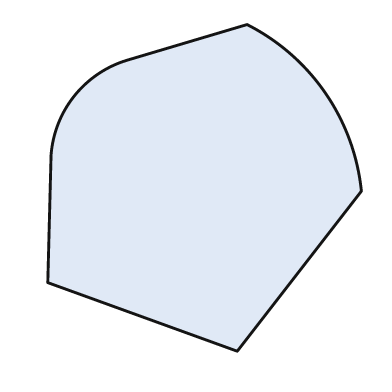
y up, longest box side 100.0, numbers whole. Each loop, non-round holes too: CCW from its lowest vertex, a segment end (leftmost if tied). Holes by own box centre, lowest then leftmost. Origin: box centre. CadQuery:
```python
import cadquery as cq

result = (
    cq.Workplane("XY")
    .moveTo(10.0, -50.0)
    .lineTo(48.0, -1.0)
    .threePointArc((37.0, 29.0), (13.0, 50.0))
    .lineTo(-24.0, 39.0)
    .threePointArc((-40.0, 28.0), (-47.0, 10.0))
    .lineTo(-48.0, -29.0)
    .close()
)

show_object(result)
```